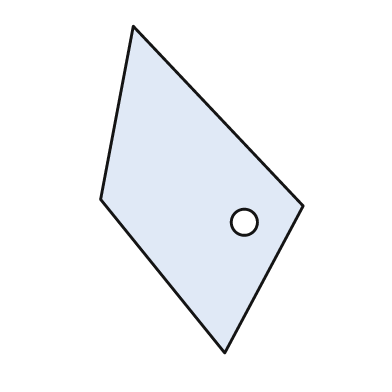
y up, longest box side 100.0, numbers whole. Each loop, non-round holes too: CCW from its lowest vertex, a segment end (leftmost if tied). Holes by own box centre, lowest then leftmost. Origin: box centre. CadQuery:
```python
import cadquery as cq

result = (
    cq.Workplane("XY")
    .moveTo(7.0, -50.0)
    .lineTo(31.0, -5.0)
    .lineTo(-21.0, 50.0)
    .lineTo(-31.0, -3.0)
    .close()
    .moveTo(13.0, -10.0)
    .circle(4.0)
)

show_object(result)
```